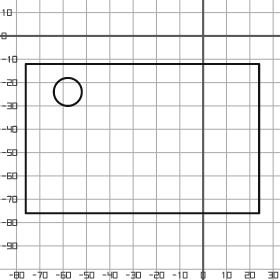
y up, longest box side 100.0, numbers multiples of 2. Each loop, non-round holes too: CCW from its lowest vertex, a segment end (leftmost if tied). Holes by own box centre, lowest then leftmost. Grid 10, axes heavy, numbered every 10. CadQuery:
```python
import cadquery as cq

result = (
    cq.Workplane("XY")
    .moveTo(-76.0, -76.0)
    .lineTo(24.0, -76.0)
    .lineTo(24.0, -12.0)
    .lineTo(-76.0, -12.0)
    .close()
    .moveTo(-58.0, -24.0)
    .circle(6.0)
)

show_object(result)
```